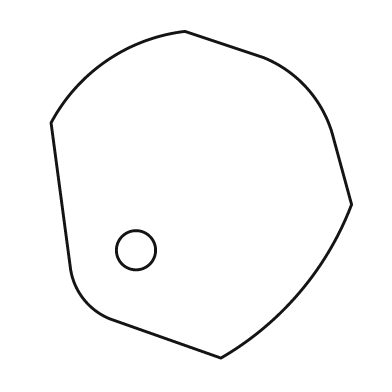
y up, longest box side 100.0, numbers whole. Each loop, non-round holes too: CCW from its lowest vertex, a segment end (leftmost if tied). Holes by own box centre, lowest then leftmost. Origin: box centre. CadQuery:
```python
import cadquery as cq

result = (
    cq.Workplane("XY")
    .moveTo(6.0, -50.0)
    .threePointArc((30.0, -30.0), (46.0, -3.0))
    .lineTo(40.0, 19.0)
    .threePointArc((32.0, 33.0), (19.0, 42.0))
    .lineTo(-5.0, 50.0)
    .threePointArc((-29.0, 41.0), (-46.0, 22.0))
    .lineTo(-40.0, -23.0)
    .threePointArc((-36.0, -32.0), (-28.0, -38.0))
    .close()
    .moveTo(-20.0, -17.0)
    .circle(6.0)
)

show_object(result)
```